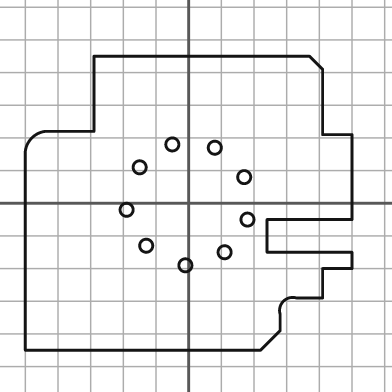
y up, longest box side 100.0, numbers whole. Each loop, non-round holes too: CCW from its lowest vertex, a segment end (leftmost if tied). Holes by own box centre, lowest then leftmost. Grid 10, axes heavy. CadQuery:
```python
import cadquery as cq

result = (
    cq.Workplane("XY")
    .moveTo(-50.0, -45.0)
    .lineTo(22.0, -45.0)
    .lineTo(28.0, -39.0)
    .lineTo(28.0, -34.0)
    .threePointArc((29.0, -30.0), (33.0, -29.0))
    .lineTo(41.0, -29.0)
    .lineTo(41.0, -20.0)
    .lineTo(50.0, -20.0)
    .lineTo(50.0, -15.0)
    .lineTo(24.0, -15.0)
    .lineTo(24.0, -5.0)
    .lineTo(50.0, -5.0)
    .lineTo(50.0, 21.0)
    .lineTo(41.0, 21.0)
    .lineTo(41.0, 41.0)
    .lineTo(37.0, 45.0)
    .lineTo(-29.0, 45.0)
    .lineTo(-29.0, 22.0)
    .lineTo(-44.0, 22.0)
    .threePointArc((-48.0, 20.0), (-50.0, 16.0))
    .close()
    .moveTo(-1.0, -19.0)
    .circle(2.0)
    .moveTo(11.0, -15.0)
    .circle(2.0)
    .moveTo(-13.0, -13.0)
    .circle(2.0)
    .moveTo(18.0, -5.0)
    .circle(2.0)
    .moveTo(-19.0, -2.0)
    .circle(2.0)
    .moveTo(17.0, 8.0)
    .circle(2.0)
    .moveTo(-15.0, 11.0)
    .circle(2.0)
    .moveTo(8.0, 17.0)
    .circle(2.0)
    .moveTo(-5.0, 18.0)
    .circle(2.0)
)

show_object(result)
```